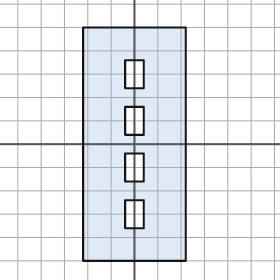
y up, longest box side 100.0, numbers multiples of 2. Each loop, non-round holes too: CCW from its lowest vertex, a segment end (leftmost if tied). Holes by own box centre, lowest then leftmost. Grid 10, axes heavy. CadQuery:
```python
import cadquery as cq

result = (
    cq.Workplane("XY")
    .moveTo(-22.0, -50.0)
    .lineTo(22.0, -50.0)
    .lineTo(22.0, 50.0)
    .lineTo(-22.0, 50.0)
    .close()
    .moveTo(-4.0, -36.0)
    .lineTo(4.0, -36.0)
    .lineTo(4.0, -24.0)
    .lineTo(-4.0, -24.0)
    .close()
    .moveTo(-4.0, -16.0)
    .lineTo(4.0, -16.0)
    .lineTo(4.0, -4.0)
    .lineTo(-4.0, -4.0)
    .close()
    .moveTo(-4.0, 4.0)
    .lineTo(4.0, 4.0)
    .lineTo(4.0, 16.0)
    .lineTo(-4.0, 16.0)
    .close()
    .moveTo(-4.0, 24.0)
    .lineTo(4.0, 24.0)
    .lineTo(4.0, 36.0)
    .lineTo(-4.0, 36.0)
    .close()
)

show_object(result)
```